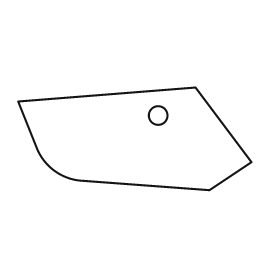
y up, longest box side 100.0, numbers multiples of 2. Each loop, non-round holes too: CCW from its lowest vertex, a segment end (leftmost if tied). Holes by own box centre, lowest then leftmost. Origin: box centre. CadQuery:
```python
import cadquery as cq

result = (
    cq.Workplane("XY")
    .moveTo(32.0, -22.0)
    .lineTo(50.0, -10.0)
    .lineTo(26.0, 22.0)
    .lineTo(-50.0, 16.0)
    .lineTo(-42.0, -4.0)
    .threePointArc((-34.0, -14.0), (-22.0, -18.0))
    .close()
    .moveTo(10.0, 10.0)
    .circle(4.0)
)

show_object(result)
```